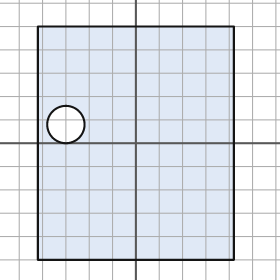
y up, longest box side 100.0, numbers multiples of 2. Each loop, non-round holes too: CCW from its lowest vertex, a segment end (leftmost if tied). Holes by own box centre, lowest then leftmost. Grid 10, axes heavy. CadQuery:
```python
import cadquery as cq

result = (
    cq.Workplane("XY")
    .moveTo(-42.0, -50.0)
    .lineTo(42.0, -50.0)
    .lineTo(42.0, 50.0)
    .lineTo(-42.0, 50.0)
    .close()
    .moveTo(-30.0, 8.0)
    .circle(8.0)
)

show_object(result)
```